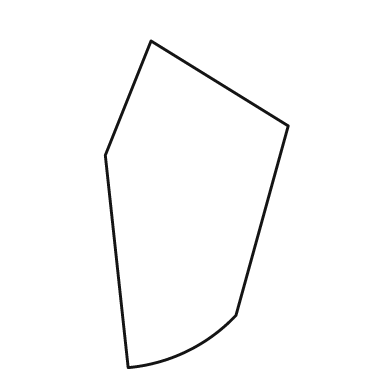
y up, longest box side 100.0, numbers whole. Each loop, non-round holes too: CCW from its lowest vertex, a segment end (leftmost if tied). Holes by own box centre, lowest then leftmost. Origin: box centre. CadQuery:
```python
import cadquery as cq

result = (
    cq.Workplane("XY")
    .moveTo(-21.0, -50.0)
    .threePointArc((-3.0, -45.0), (12.0, -34.0))
    .lineTo(28.0, 24.0)
    .lineTo(-14.0, 50.0)
    .lineTo(-28.0, 15.0)
    .close()
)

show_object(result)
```